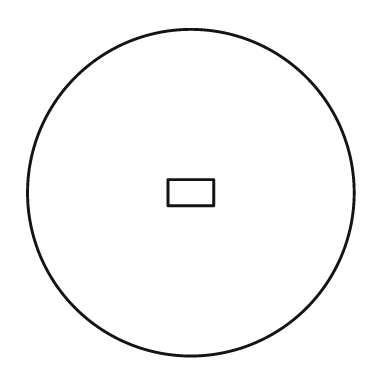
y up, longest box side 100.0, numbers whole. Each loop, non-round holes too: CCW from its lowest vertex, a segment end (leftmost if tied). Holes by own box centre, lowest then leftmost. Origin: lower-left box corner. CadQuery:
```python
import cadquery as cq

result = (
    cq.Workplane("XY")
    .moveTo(50.0, 50.0)
    .circle(50.0)
    .moveTo(43.0, 46.0)
    .lineTo(57.0, 46.0)
    .lineTo(57.0, 54.0)
    .lineTo(43.0, 54.0)
    .close()
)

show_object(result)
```